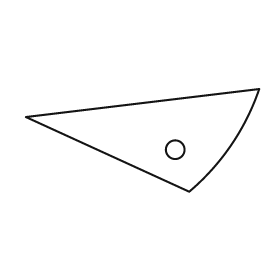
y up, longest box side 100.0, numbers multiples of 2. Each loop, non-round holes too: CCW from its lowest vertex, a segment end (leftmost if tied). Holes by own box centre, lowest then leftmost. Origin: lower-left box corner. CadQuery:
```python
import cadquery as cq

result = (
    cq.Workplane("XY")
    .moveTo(70.0, 0.0)
    .threePointArc((88.0, 20.0), (100.0, 44.0))
    .lineTo(0.0, 32.0)
    .close()
    .moveTo(64.0, 18.0)
    .circle(4.0)
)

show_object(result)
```